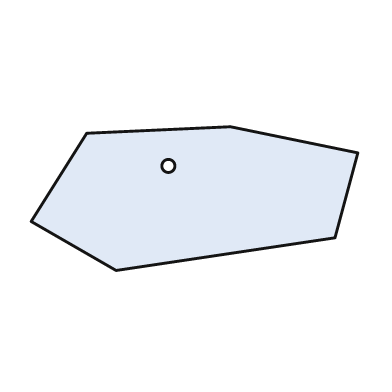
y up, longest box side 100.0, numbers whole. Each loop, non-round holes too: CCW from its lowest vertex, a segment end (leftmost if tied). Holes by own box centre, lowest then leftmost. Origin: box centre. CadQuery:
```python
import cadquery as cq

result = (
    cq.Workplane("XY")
    .moveTo(-24.0, -22.0)
    .lineTo(43.0, -12.0)
    .lineTo(50.0, 14.0)
    .lineTo(11.0, 22.0)
    .lineTo(-33.0, 20.0)
    .lineTo(-50.0, -7.0)
    .close()
    .moveTo(-8.0, 10.0)
    .circle(2.0)
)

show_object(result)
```